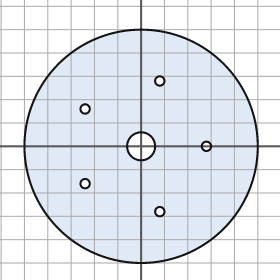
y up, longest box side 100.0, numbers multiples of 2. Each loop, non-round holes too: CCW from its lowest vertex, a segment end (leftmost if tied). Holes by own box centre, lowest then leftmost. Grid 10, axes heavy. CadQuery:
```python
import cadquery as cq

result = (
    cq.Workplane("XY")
    .moveTo(0.0, 0.0)
    .circle(50.0)
    .moveTo(8.0, -28.0)
    .circle(2.0)
    .moveTo(-24.0, -16.0)
    .circle(2.0)
    .moveTo(0.0, 0.0)
    .circle(6.0)
    .moveTo(28.0, 0.0)
    .circle(2.0)
    .moveTo(-24.0, 16.0)
    .circle(2.0)
    .moveTo(8.0, 28.0)
    .circle(2.0)
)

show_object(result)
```